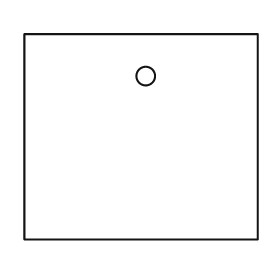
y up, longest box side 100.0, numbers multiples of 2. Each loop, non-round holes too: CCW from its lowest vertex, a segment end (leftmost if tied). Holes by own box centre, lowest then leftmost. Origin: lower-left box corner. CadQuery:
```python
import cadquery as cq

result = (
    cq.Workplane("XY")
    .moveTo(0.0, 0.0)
    .lineTo(100.0, 0.0)
    .lineTo(100.0, 88.0)
    .lineTo(0.0, 88.0)
    .close()
    .moveTo(52.0, 70.0)
    .circle(4.0)
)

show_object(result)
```